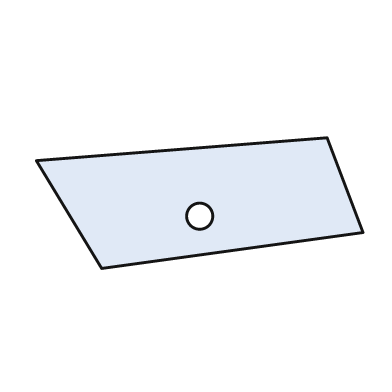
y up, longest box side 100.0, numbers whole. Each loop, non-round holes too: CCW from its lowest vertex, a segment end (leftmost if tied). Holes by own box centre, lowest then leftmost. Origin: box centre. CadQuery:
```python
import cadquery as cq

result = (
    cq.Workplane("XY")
    .moveTo(-30.0, -20.0)
    .lineTo(50.0, -9.0)
    .lineTo(39.0, 20.0)
    .lineTo(-50.0, 13.0)
    .close()
    .moveTo(0.0, -4.0)
    .circle(4.0)
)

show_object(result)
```